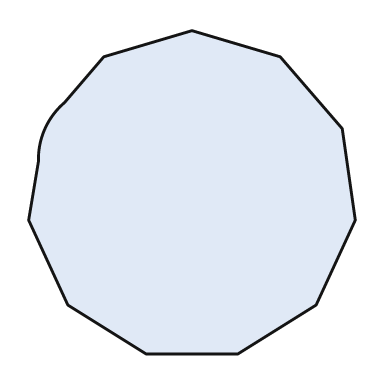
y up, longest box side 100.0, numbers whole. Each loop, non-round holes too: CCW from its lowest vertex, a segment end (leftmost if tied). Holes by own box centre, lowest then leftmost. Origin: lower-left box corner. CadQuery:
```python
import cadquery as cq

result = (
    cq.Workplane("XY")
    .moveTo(36.0, 0.0)
    .lineTo(64.0, 0.0)
    .lineTo(88.0, 15.0)
    .lineTo(100.0, 41.0)
    .lineTo(96.0, 69.0)
    .lineTo(77.0, 91.0)
    .lineTo(50.0, 99.0)
    .lineTo(23.0, 91.0)
    .lineTo(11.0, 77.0)
    .threePointArc((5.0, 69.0), (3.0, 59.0))
    .lineTo(0.0, 41.0)
    .lineTo(12.0, 15.0)
    .close()
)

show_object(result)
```